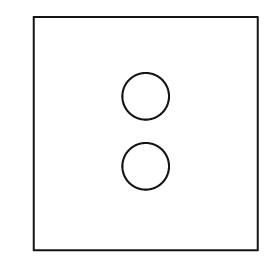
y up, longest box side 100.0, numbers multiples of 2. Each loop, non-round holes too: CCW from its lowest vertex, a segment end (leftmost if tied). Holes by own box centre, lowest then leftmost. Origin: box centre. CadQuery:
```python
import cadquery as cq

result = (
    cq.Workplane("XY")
    .moveTo(-48.0, -50.0)
    .lineTo(48.0, -50.0)
    .lineTo(48.0, 50.0)
    .lineTo(-48.0, 50.0)
    .close()
    .moveTo(0.0, -14.0)
    .circle(10.0)
    .moveTo(0.0, 16.0)
    .circle(10.0)
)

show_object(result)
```